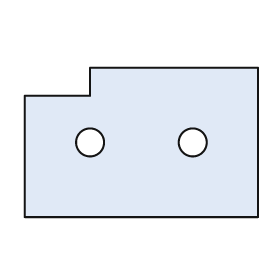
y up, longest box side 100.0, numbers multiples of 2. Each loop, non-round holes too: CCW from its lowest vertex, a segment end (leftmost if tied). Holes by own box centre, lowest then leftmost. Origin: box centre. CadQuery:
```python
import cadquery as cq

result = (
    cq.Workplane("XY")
    .moveTo(-50.0, -32.0)
    .lineTo(50.0, -32.0)
    .lineTo(50.0, 32.0)
    .lineTo(-22.0, 32.0)
    .lineTo(-22.0, 20.0)
    .lineTo(-50.0, 20.0)
    .close()
    .moveTo(-22.0, 0.0)
    .circle(6.0)
    .moveTo(22.0, 0.0)
    .circle(6.0)
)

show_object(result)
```